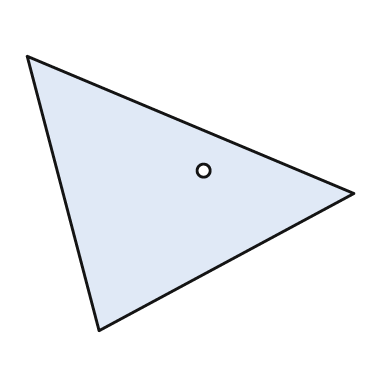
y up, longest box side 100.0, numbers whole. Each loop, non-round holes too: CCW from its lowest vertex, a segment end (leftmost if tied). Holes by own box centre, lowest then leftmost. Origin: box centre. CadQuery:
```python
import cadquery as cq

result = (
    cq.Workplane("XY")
    .moveTo(-28.0, -42.0)
    .lineTo(50.0, 0.0)
    .lineTo(-50.0, 42.0)
    .close()
    .moveTo(4.0, 7.0)
    .circle(2.0)
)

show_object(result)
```